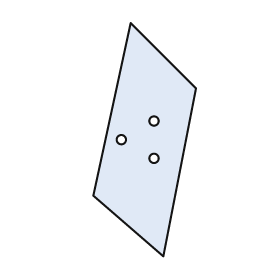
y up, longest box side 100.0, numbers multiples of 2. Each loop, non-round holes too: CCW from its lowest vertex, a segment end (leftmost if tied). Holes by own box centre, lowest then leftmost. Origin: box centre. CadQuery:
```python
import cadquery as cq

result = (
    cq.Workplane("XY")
    .moveTo(8.0, -50.0)
    .lineTo(22.0, 22.0)
    .lineTo(-6.0, 50.0)
    .lineTo(-22.0, -24.0)
    .close()
    .moveTo(4.0, -8.0)
    .circle(2.0)
    .moveTo(-10.0, 0.0)
    .circle(2.0)
    .moveTo(4.0, 8.0)
    .circle(2.0)
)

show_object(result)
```